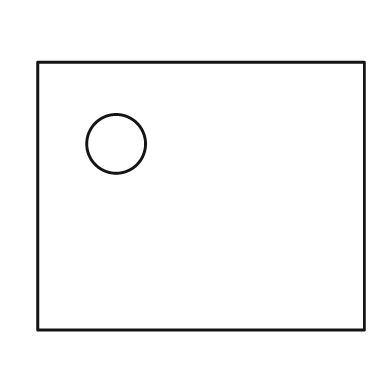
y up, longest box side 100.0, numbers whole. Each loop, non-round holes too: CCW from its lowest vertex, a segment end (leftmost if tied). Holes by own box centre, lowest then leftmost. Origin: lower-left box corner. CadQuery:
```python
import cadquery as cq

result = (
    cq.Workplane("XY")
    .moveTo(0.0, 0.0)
    .lineTo(100.0, 0.0)
    .lineTo(100.0, 82.0)
    .lineTo(0.0, 82.0)
    .close()
    .moveTo(24.0, 57.0)
    .circle(9.0)
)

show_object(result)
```